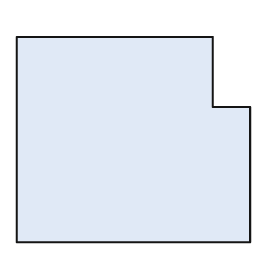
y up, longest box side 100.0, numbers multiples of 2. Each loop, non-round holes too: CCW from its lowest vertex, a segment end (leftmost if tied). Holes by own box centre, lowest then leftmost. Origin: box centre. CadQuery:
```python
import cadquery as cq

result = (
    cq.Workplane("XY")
    .moveTo(-50.0, -44.0)
    .lineTo(50.0, -44.0)
    .lineTo(50.0, 14.0)
    .lineTo(34.0, 14.0)
    .lineTo(34.0, 44.0)
    .lineTo(-50.0, 44.0)
    .close()
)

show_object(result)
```